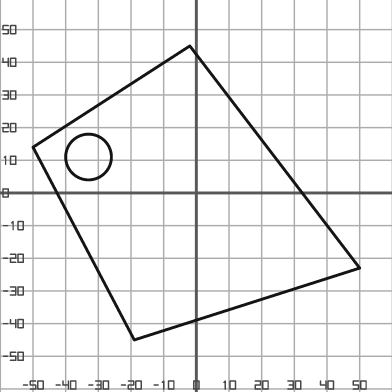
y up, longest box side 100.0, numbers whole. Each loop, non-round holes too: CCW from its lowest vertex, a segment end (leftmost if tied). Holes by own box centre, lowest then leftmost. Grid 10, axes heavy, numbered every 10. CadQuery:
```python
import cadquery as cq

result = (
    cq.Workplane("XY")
    .moveTo(-19.0, -45.0)
    .lineTo(50.0, -23.0)
    .lineTo(-2.0, 45.0)
    .lineTo(-50.0, 14.0)
    .close()
    .moveTo(-33.0, 11.0)
    .circle(7.0)
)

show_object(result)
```